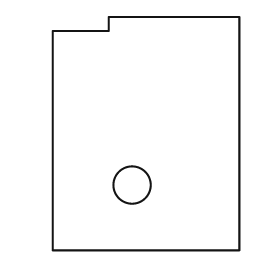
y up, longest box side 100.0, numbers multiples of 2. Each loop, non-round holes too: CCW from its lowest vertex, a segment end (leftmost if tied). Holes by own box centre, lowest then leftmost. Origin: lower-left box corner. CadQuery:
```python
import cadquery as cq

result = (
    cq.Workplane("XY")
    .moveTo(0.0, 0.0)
    .lineTo(80.0, 0.0)
    .lineTo(80.0, 100.0)
    .lineTo(24.0, 100.0)
    .lineTo(24.0, 94.0)
    .lineTo(0.0, 94.0)
    .close()
    .moveTo(34.0, 28.0)
    .circle(8.0)
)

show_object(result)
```